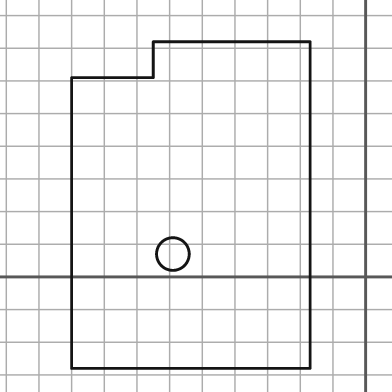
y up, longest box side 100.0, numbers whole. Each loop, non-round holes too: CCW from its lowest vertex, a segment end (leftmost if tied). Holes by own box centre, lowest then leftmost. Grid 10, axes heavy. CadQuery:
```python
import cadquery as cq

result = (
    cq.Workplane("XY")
    .moveTo(-90.0, -28.0)
    .lineTo(-17.0, -28.0)
    .lineTo(-17.0, 72.0)
    .lineTo(-65.0, 72.0)
    .lineTo(-65.0, 61.0)
    .lineTo(-90.0, 61.0)
    .close()
    .moveTo(-59.0, 7.0)
    .circle(5.0)
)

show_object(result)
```